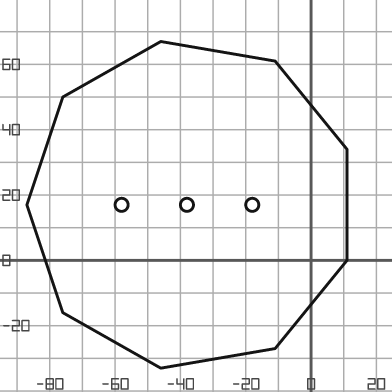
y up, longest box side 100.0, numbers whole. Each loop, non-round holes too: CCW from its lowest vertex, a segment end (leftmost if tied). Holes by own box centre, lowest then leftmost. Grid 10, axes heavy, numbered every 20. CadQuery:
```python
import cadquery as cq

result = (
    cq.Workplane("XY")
    .moveTo(-46.0, -33.0)
    .lineTo(-11.0, -27.0)
    .lineTo(11.0, 0.0)
    .lineTo(11.0, 34.0)
    .lineTo(-11.0, 61.0)
    .lineTo(-46.0, 67.0)
    .lineTo(-76.0, 50.0)
    .lineTo(-87.0, 17.0)
    .lineTo(-76.0, -16.0)
    .close()
    .moveTo(-58.0, 17.0)
    .circle(2.0)
    .moveTo(-38.0, 17.0)
    .circle(2.0)
    .moveTo(-18.0, 17.0)
    .circle(2.0)
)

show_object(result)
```